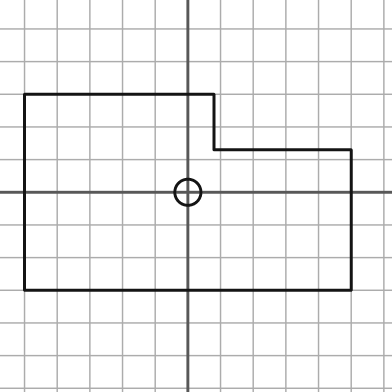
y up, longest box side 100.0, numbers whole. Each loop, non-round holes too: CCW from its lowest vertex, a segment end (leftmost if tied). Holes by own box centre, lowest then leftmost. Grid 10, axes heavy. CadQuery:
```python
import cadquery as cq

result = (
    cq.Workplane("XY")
    .moveTo(-50.0, -30.0)
    .lineTo(50.0, -30.0)
    .lineTo(50.0, 13.0)
    .lineTo(8.0, 13.0)
    .lineTo(8.0, 30.0)
    .lineTo(-50.0, 30.0)
    .close()
    .moveTo(0.0, 0.0)
    .circle(4.0)
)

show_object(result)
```